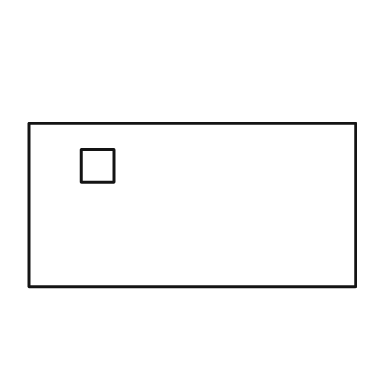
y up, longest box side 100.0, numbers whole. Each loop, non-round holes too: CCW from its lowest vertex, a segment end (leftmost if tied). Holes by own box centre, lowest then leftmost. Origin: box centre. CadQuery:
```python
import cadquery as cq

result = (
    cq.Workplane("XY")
    .moveTo(-50.0, -25.0)
    .lineTo(50.0, -25.0)
    .lineTo(50.0, 25.0)
    .lineTo(-50.0, 25.0)
    .close()
    .moveTo(-34.0, 7.0)
    .lineTo(-24.0, 7.0)
    .lineTo(-24.0, 17.0)
    .lineTo(-34.0, 17.0)
    .close()
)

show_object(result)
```